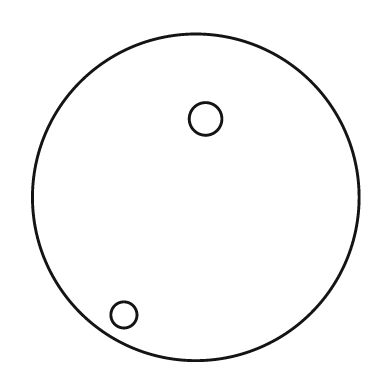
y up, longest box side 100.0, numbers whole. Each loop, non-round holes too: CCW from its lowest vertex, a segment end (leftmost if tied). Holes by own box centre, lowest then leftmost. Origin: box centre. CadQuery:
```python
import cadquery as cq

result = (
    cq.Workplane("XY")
    .moveTo(0.0, 0.0)
    .circle(50.0)
    .moveTo(-22.0, -36.0)
    .circle(4.0)
    .moveTo(3.0, 24.0)
    .circle(5.0)
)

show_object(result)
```